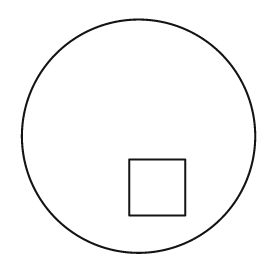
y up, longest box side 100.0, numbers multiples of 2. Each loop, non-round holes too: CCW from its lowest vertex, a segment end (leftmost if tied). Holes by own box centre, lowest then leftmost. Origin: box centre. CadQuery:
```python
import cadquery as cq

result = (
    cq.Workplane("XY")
    .moveTo(0.0, 0.0)
    .circle(50.0)
    .moveTo(-4.0, -34.0)
    .lineTo(20.0, -34.0)
    .lineTo(20.0, -10.0)
    .lineTo(-4.0, -10.0)
    .close()
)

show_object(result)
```